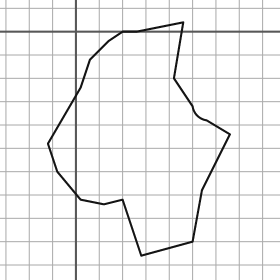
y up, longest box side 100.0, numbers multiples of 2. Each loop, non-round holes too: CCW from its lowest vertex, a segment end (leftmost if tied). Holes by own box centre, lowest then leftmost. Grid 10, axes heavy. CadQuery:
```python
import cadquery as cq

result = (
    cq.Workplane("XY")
    .moveTo(28.0, -96.0)
    .lineTo(50.0, -90.0)
    .lineTo(54.0, -68.0)
    .lineTo(66.0, -44.0)
    .lineTo(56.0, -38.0)
    .threePointArc((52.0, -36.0), (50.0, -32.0))
    .lineTo(42.0, -20.0)
    .lineTo(46.0, 4.0)
    .lineTo(26.0, 0.0)
    .lineTo(20.0, 0.0)
    .lineTo(14.0, -4.0)
    .lineTo(6.0, -12.0)
    .lineTo(2.0, -24.0)
    .lineTo(-12.0, -48.0)
    .lineTo(-8.0, -60.0)
    .lineTo(2.0, -72.0)
    .lineTo(12.0, -74.0)
    .lineTo(20.0, -72.0)
    .close()
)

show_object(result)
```